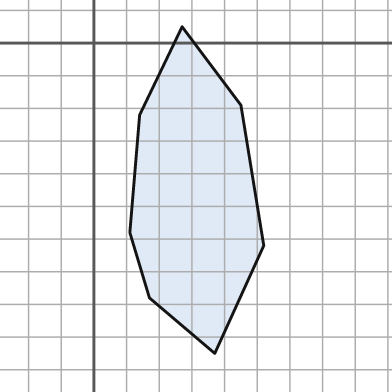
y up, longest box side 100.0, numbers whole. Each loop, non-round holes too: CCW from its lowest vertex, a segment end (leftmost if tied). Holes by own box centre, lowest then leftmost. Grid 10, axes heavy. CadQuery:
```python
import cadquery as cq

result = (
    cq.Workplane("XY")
    .moveTo(37.0, -95.0)
    .lineTo(52.0, -62.0)
    .lineTo(45.0, -19.0)
    .lineTo(27.0, 5.0)
    .lineTo(14.0, -22.0)
    .lineTo(11.0, -58.0)
    .lineTo(17.0, -78.0)
    .close()
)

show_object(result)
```